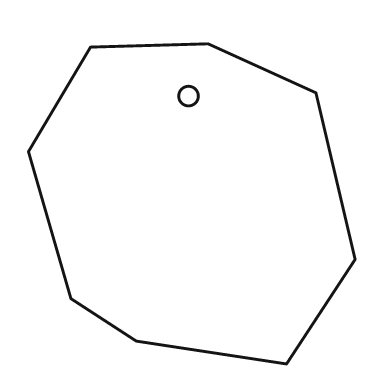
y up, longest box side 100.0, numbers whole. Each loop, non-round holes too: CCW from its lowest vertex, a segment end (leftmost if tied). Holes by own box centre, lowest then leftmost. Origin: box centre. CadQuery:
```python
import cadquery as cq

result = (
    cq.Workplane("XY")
    .moveTo(29.0, -49.0)
    .lineTo(50.0, -17.0)
    .lineTo(38.0, 34.0)
    .lineTo(5.0, 49.0)
    .lineTo(-31.0, 48.0)
    .lineTo(-50.0, 16.0)
    .lineTo(-37.0, -29.0)
    .lineTo(-17.0, -42.0)
    .close()
    .moveTo(-1.0, 33.0)
    .circle(3.0)
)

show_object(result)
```